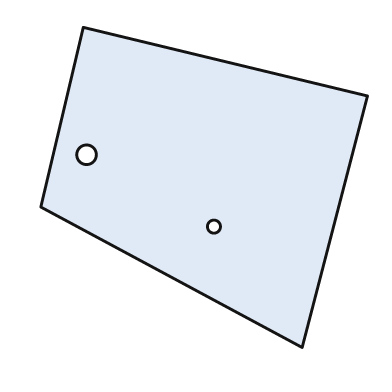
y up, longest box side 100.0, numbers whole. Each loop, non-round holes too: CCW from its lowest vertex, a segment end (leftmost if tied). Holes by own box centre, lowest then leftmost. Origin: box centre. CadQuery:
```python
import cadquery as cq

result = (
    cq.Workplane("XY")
    .moveTo(30.0, -49.0)
    .lineTo(50.0, 28.0)
    .lineTo(-37.0, 49.0)
    .lineTo(-50.0, -6.0)
    .close()
    .moveTo(3.0, -12.0)
    .circle(2.0)
    .moveTo(-36.0, 10.0)
    .circle(3.0)
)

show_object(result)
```